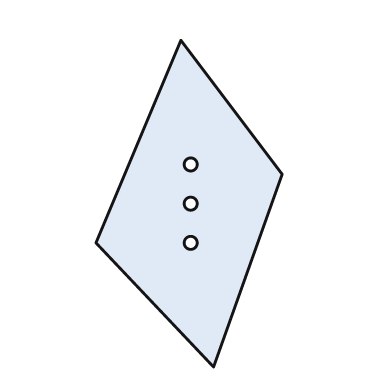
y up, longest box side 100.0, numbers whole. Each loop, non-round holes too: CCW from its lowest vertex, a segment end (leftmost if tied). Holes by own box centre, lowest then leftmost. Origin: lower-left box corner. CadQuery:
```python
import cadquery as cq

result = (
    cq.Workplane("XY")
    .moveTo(36.0, 0.0)
    .lineTo(57.0, 59.0)
    .lineTo(26.0, 100.0)
    .lineTo(0.0, 38.0)
    .close()
    .moveTo(29.0, 38.0)
    .circle(2.0)
    .moveTo(29.0, 50.0)
    .circle(2.0)
    .moveTo(29.0, 62.0)
    .circle(2.0)
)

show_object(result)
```